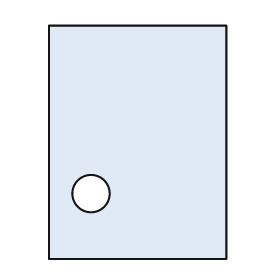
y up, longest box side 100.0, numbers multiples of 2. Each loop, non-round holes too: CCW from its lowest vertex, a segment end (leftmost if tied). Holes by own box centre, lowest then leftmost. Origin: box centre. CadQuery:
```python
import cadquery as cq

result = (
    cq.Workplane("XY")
    .moveTo(-38.0, -50.0)
    .lineTo(38.0, -50.0)
    .lineTo(38.0, 50.0)
    .lineTo(-38.0, 50.0)
    .close()
    .moveTo(-20.0, -22.0)
    .circle(8.0)
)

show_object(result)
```